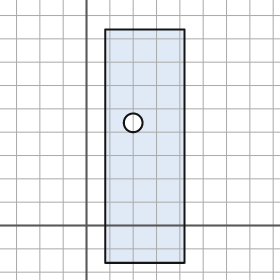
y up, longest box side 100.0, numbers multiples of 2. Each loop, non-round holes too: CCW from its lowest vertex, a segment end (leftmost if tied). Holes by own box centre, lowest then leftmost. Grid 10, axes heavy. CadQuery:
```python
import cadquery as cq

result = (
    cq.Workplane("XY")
    .moveTo(8.0, -16.0)
    .lineTo(42.0, -16.0)
    .lineTo(42.0, 84.0)
    .lineTo(8.0, 84.0)
    .close()
    .moveTo(20.0, 44.0)
    .circle(4.0)
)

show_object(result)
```